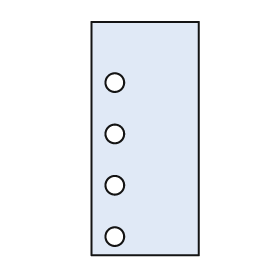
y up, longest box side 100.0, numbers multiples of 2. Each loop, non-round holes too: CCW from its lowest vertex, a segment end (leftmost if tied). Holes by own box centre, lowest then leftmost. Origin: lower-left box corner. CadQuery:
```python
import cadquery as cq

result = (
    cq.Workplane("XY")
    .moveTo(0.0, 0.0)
    .lineTo(46.0, 0.0)
    .lineTo(46.0, 100.0)
    .lineTo(0.0, 100.0)
    .close()
    .moveTo(10.0, 8.0)
    .circle(4.0)
    .moveTo(10.0, 30.0)
    .circle(4.0)
    .moveTo(10.0, 52.0)
    .circle(4.0)
    .moveTo(10.0, 74.0)
    .circle(4.0)
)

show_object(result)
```